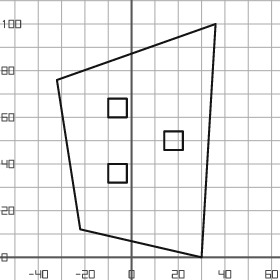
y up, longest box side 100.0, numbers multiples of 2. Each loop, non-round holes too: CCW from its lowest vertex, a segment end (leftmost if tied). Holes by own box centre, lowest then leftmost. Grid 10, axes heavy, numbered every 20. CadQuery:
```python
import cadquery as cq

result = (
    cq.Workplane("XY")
    .moveTo(30.0, 0.0)
    .lineTo(36.0, 100.0)
    .lineTo(-32.0, 76.0)
    .lineTo(-22.0, 12.0)
    .close()
    .moveTo(-10.0, 32.0)
    .lineTo(-2.0, 32.0)
    .lineTo(-2.0, 40.0)
    .lineTo(-10.0, 40.0)
    .close()
    .moveTo(14.0, 46.0)
    .lineTo(22.0, 46.0)
    .lineTo(22.0, 54.0)
    .lineTo(14.0, 54.0)
    .close()
    .moveTo(-10.0, 60.0)
    .lineTo(-2.0, 60.0)
    .lineTo(-2.0, 68.0)
    .lineTo(-10.0, 68.0)
    .close()
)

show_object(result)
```